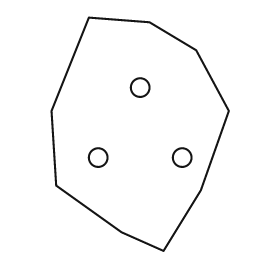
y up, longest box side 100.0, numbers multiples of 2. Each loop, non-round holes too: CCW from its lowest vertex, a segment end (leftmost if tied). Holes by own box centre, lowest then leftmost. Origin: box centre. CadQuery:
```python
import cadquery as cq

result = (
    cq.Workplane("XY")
    .moveTo(10.0, -50.0)
    .lineTo(26.0, -24.0)
    .lineTo(38.0, 10.0)
    .lineTo(24.0, 36.0)
    .lineTo(4.0, 48.0)
    .lineTo(-22.0, 50.0)
    .lineTo(-38.0, 10.0)
    .lineTo(-36.0, -22.0)
    .lineTo(-8.0, -42.0)
    .close()
    .moveTo(-18.0, -10.0)
    .circle(4.0)
    .moveTo(18.0, -10.0)
    .circle(4.0)
    .moveTo(0.0, 20.0)
    .circle(4.0)
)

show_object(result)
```